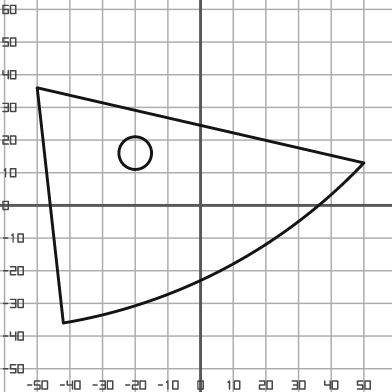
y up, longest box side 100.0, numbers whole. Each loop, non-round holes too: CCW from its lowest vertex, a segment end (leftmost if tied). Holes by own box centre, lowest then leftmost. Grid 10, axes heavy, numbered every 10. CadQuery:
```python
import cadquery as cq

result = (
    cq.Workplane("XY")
    .moveTo(-42.0, -36.0)
    .threePointArc((8.0, -19.0), (50.0, 13.0))
    .lineTo(-50.0, 36.0)
    .close()
    .moveTo(-20.0, 16.0)
    .circle(5.0)
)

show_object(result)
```